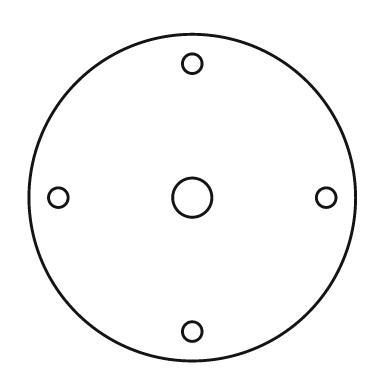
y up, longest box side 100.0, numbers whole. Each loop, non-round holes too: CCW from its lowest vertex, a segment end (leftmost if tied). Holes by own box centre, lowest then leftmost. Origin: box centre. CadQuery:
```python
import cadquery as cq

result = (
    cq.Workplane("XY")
    .moveTo(0.0, 0.0)
    .circle(50.0)
    .moveTo(0.0, -41.0)
    .circle(3.0)
    .moveTo(-41.0, 0.0)
    .circle(3.0)
    .moveTo(0.0, 0.0)
    .circle(6.0)
    .moveTo(41.0, 0.0)
    .circle(3.0)
    .moveTo(0.0, 41.0)
    .circle(3.0)
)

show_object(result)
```